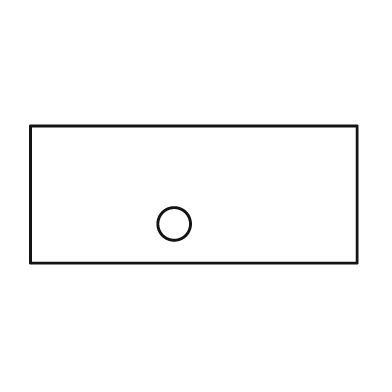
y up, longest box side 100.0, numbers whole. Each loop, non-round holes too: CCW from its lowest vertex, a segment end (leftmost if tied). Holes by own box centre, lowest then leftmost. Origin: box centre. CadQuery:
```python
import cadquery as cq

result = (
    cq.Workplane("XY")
    .moveTo(-50.0, -21.0)
    .lineTo(50.0, -21.0)
    .lineTo(50.0, 21.0)
    .lineTo(-50.0, 21.0)
    .close()
    .moveTo(-6.0, -9.0)
    .circle(5.0)
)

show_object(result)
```